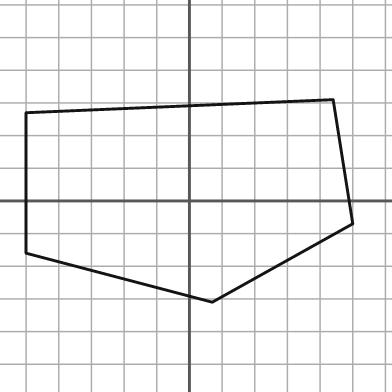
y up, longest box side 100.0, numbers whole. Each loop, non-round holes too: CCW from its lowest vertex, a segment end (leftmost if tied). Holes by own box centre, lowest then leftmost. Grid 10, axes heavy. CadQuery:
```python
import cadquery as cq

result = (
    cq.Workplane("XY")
    .moveTo(7.0, -31.0)
    .lineTo(50.0, -7.0)
    .lineTo(44.0, 31.0)
    .lineTo(-50.0, 27.0)
    .lineTo(-50.0, -16.0)
    .close()
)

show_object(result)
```